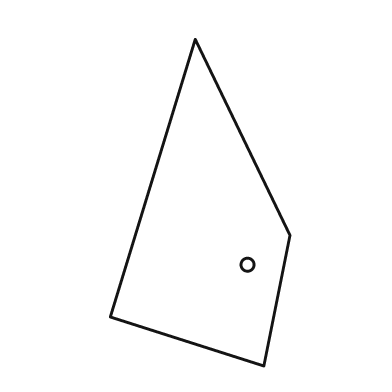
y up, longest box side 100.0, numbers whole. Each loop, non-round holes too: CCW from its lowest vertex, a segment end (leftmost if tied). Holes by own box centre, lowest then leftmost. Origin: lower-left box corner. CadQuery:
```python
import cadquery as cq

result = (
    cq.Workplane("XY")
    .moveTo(47.0, 0.0)
    .lineTo(55.0, 40.0)
    .lineTo(26.0, 100.0)
    .lineTo(0.0, 15.0)
    .close()
    .moveTo(42.0, 31.0)
    .circle(2.0)
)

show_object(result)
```